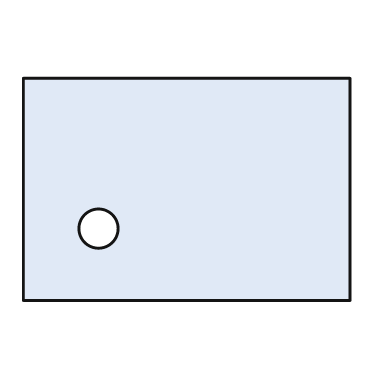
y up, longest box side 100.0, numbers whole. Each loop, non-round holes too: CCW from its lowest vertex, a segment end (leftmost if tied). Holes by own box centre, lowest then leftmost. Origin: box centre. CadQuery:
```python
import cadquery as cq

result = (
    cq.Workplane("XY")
    .moveTo(-50.0, -34.0)
    .lineTo(50.0, -34.0)
    .lineTo(50.0, 34.0)
    .lineTo(-50.0, 34.0)
    .close()
    .moveTo(-27.0, -12.0)
    .circle(6.0)
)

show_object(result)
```